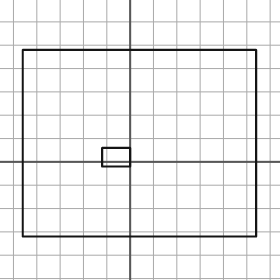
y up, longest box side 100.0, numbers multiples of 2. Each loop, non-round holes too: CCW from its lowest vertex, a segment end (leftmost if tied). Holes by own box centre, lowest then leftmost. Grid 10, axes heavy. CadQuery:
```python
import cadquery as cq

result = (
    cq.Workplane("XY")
    .moveTo(-46.0, -32.0)
    .lineTo(54.0, -32.0)
    .lineTo(54.0, 48.0)
    .lineTo(-46.0, 48.0)
    .close()
    .moveTo(-12.0, -2.0)
    .lineTo(0.0, -2.0)
    .lineTo(0.0, 6.0)
    .lineTo(-12.0, 6.0)
    .close()
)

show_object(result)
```